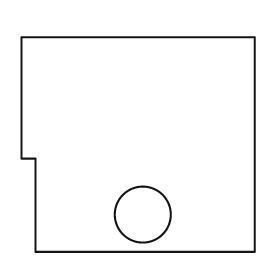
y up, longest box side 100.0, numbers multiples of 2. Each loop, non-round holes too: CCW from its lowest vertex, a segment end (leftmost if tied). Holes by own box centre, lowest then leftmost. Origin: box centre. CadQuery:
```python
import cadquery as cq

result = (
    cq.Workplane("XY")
    .moveTo(-44.0, -46.0)
    .lineTo(50.0, -46.0)
    .lineTo(50.0, 46.0)
    .lineTo(-50.0, 46.0)
    .lineTo(-50.0, -6.0)
    .lineTo(-44.0, -6.0)
    .close()
    .moveTo(2.0, -30.0)
    .circle(12.0)
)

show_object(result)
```